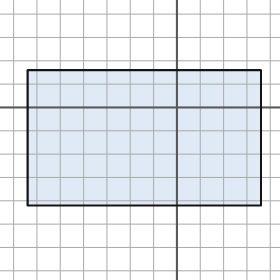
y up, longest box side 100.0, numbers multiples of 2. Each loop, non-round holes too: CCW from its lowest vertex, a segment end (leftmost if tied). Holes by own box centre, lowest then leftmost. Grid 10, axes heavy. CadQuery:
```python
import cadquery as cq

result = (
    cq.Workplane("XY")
    .moveTo(-64.0, -42.0)
    .lineTo(36.0, -42.0)
    .lineTo(36.0, 16.0)
    .lineTo(-64.0, 16.0)
    .close()
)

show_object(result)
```